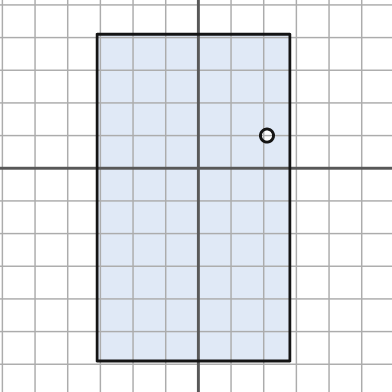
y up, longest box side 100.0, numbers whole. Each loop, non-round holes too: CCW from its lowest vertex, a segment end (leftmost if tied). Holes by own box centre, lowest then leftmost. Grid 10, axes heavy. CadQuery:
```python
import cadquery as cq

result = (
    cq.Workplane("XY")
    .moveTo(-31.0, -59.0)
    .lineTo(28.0, -59.0)
    .lineTo(28.0, 41.0)
    .lineTo(-31.0, 41.0)
    .close()
    .moveTo(21.0, 10.0)
    .circle(2.0)
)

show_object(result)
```